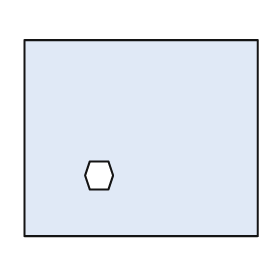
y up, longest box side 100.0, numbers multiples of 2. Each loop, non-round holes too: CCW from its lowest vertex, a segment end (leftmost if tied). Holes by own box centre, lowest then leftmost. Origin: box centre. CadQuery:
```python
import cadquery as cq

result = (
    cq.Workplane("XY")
    .moveTo(-50.0, -42.0)
    .lineTo(50.0, -42.0)
    .lineTo(50.0, 42.0)
    .lineTo(-50.0, 42.0)
    .close()
    .moveTo(-22.0, -22.0)
    .lineTo(-14.0, -22.0)
    .lineTo(-12.0, -16.0)
    .lineTo(-14.0, -10.0)
    .lineTo(-22.0, -10.0)
    .lineTo(-24.0, -16.0)
    .close()
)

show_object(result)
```